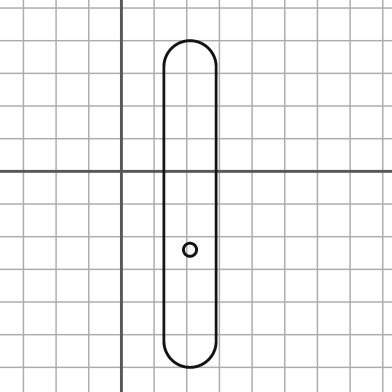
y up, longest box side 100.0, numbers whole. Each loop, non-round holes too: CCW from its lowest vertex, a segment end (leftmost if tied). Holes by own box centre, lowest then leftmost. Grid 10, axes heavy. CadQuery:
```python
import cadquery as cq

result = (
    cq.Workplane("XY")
    .moveTo(13.0, -52.0)
    .threePointArc((21.0, -60.0), (29.0, -52.0))
    .lineTo(29.0, 32.0)
    .threePointArc((21.0, 40.0), (13.0, 32.0))
    .close()
    .moveTo(21.0, -24.0)
    .circle(2.0)
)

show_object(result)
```